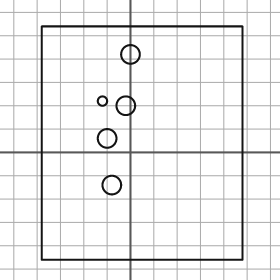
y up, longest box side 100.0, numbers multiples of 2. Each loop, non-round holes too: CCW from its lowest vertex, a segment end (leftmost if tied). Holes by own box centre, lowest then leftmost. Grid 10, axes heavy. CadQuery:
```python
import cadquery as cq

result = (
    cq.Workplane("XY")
    .moveTo(-38.0, -46.0)
    .lineTo(48.0, -46.0)
    .lineTo(48.0, 54.0)
    .lineTo(-38.0, 54.0)
    .close()
    .moveTo(-8.0, -14.0)
    .circle(4.0)
    .moveTo(-10.0, 6.0)
    .circle(4.0)
    .moveTo(-2.0, 20.0)
    .circle(4.0)
    .moveTo(-12.0, 22.0)
    .circle(2.0)
    .moveTo(0.0, 42.0)
    .circle(4.0)
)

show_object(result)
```